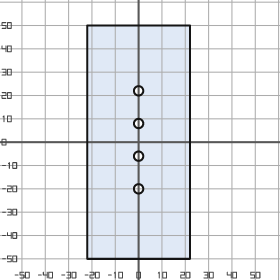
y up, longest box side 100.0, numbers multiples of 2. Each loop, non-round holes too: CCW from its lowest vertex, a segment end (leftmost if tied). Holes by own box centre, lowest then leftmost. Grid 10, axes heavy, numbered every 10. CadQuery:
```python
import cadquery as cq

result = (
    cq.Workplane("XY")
    .moveTo(-22.0, -50.0)
    .lineTo(22.0, -50.0)
    .lineTo(22.0, 50.0)
    .lineTo(-22.0, 50.0)
    .close()
    .moveTo(0.0, -20.0)
    .circle(2.0)
    .moveTo(0.0, -6.0)
    .circle(2.0)
    .moveTo(0.0, 8.0)
    .circle(2.0)
    .moveTo(0.0, 22.0)
    .circle(2.0)
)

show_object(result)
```